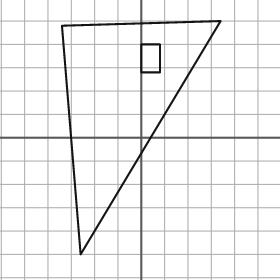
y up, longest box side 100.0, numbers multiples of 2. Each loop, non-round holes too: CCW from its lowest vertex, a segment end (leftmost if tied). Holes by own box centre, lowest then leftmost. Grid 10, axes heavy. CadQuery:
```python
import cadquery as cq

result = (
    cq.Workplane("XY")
    .moveTo(-26.0, -50.0)
    .lineTo(34.0, 50.0)
    .lineTo(-34.0, 48.0)
    .close()
    .moveTo(0.0, 28.0)
    .lineTo(8.0, 28.0)
    .lineTo(8.0, 40.0)
    .lineTo(0.0, 40.0)
    .close()
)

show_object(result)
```